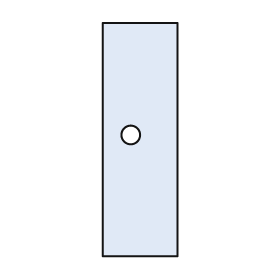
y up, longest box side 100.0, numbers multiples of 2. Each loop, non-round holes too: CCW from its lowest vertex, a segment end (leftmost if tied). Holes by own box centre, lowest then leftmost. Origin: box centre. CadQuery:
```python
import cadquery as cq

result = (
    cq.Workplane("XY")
    .moveTo(-16.0, -50.0)
    .lineTo(16.0, -50.0)
    .lineTo(16.0, 50.0)
    .lineTo(-16.0, 50.0)
    .close()
    .moveTo(-4.0, 2.0)
    .circle(4.0)
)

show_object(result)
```